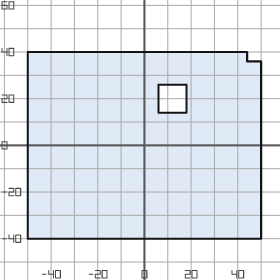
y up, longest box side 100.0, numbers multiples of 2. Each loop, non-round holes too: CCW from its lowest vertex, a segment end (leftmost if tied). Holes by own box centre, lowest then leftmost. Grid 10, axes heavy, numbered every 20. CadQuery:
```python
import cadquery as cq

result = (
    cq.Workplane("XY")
    .moveTo(-50.0, -40.0)
    .lineTo(50.0, -40.0)
    .lineTo(50.0, 36.0)
    .lineTo(44.0, 36.0)
    .lineTo(44.0, 40.0)
    .lineTo(-50.0, 40.0)
    .close()
    .moveTo(6.0, 14.0)
    .lineTo(18.0, 14.0)
    .lineTo(18.0, 26.0)
    .lineTo(6.0, 26.0)
    .close()
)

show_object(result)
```